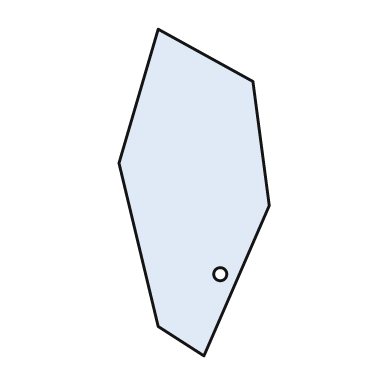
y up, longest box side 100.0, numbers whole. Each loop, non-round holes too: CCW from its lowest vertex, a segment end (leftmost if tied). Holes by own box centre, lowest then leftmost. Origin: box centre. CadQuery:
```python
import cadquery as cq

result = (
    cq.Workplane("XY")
    .moveTo(3.0, -50.0)
    .lineTo(23.0, -4.0)
    .lineTo(18.0, 34.0)
    .lineTo(-11.0, 50.0)
    .lineTo(-23.0, 9.0)
    .lineTo(-11.0, -41.0)
    .close()
    .moveTo(8.0, -25.0)
    .circle(2.0)
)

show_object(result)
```